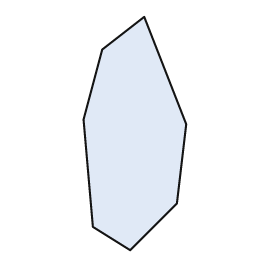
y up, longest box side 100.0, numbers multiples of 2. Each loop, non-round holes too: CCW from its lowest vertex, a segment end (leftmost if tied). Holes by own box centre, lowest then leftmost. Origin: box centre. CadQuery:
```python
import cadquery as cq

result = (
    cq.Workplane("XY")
    .moveTo(-2.0, -50.0)
    .lineTo(18.0, -30.0)
    .lineTo(22.0, 4.0)
    .lineTo(4.0, 50.0)
    .lineTo(-14.0, 36.0)
    .lineTo(-22.0, 6.0)
    .lineTo(-18.0, -40.0)
    .close()
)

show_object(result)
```